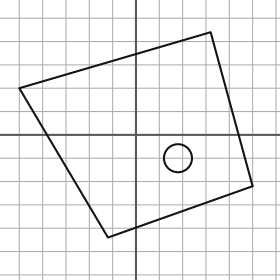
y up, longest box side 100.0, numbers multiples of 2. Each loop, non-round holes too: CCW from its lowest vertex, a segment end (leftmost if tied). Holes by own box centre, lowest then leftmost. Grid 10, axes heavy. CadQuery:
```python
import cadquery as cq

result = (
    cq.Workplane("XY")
    .moveTo(-12.0, -44.0)
    .lineTo(50.0, -22.0)
    .lineTo(32.0, 44.0)
    .lineTo(-50.0, 20.0)
    .close()
    .moveTo(18.0, -10.0)
    .circle(6.0)
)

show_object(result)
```